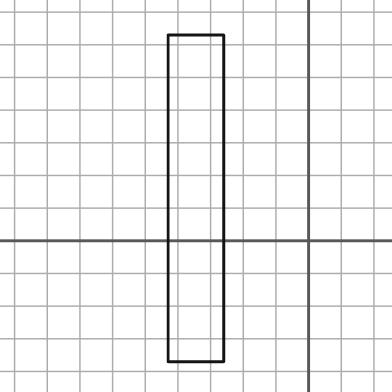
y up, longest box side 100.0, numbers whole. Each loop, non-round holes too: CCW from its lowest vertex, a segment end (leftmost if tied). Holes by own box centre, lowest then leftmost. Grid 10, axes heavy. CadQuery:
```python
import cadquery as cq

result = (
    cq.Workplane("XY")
    .moveTo(-43.0, -37.0)
    .lineTo(-26.0, -37.0)
    .lineTo(-26.0, 63.0)
    .lineTo(-43.0, 63.0)
    .close()
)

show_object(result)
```